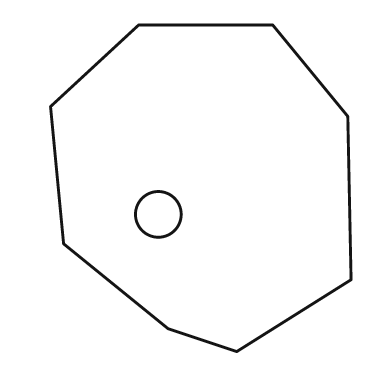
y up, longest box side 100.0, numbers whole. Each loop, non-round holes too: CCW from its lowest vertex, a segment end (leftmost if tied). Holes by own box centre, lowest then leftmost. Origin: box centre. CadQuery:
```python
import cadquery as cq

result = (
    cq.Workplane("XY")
    .moveTo(11.0, -50.0)
    .lineTo(46.0, -28.0)
    .lineTo(45.0, 22.0)
    .lineTo(22.0, 50.0)
    .lineTo(-19.0, 50.0)
    .lineTo(-46.0, 25.0)
    .lineTo(-42.0, -17.0)
    .lineTo(-10.0, -43.0)
    .close()
    .moveTo(-13.0, -8.0)
    .circle(7.0)
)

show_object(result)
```